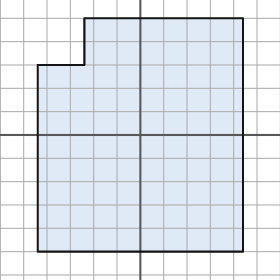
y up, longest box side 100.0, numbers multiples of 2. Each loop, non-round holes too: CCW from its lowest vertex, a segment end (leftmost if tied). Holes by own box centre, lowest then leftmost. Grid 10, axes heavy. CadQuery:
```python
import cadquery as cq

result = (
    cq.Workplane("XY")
    .moveTo(-44.0, -50.0)
    .lineTo(44.0, -50.0)
    .lineTo(44.0, 50.0)
    .lineTo(-24.0, 50.0)
    .lineTo(-24.0, 30.0)
    .lineTo(-44.0, 30.0)
    .close()
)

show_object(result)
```